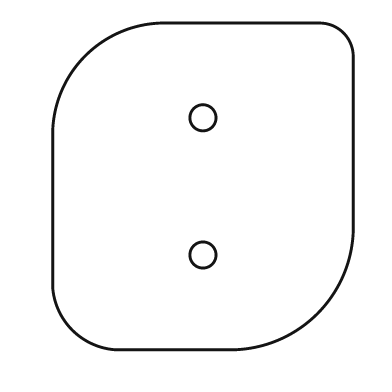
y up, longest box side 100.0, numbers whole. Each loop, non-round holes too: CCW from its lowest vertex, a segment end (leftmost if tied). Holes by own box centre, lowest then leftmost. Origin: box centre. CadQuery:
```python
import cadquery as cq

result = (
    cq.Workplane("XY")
    .moveTo(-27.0, -50.0)
    .lineTo(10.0, -50.0)
    .threePointArc((35.0, -39.0), (46.0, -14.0))
    .lineTo(46.0, 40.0)
    .threePointArc((43.0, 47.0), (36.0, 50.0))
    .lineTo(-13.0, 50.0)
    .threePointArc((-36.0, 40.0), (-46.0, 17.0))
    .lineTo(-46.0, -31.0)
    .threePointArc((-40.0, -44.0), (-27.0, -50.0))
    .close()
    .moveTo(0.0, -21.0)
    .circle(4.0)
    .moveTo(0.0, 21.0)
    .circle(4.0)
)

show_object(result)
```